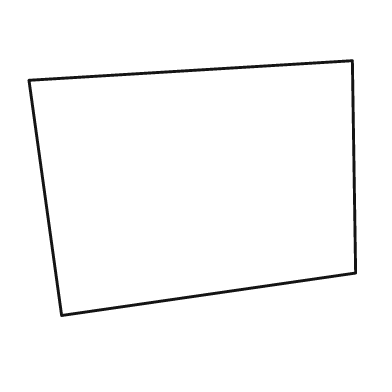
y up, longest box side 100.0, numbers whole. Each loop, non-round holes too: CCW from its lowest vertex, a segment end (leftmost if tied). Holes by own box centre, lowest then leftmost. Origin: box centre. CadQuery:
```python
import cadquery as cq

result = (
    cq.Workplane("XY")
    .moveTo(-40.0, -39.0)
    .lineTo(50.0, -26.0)
    .lineTo(49.0, 39.0)
    .lineTo(-50.0, 33.0)
    .close()
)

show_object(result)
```